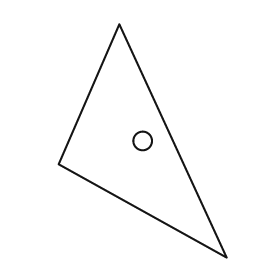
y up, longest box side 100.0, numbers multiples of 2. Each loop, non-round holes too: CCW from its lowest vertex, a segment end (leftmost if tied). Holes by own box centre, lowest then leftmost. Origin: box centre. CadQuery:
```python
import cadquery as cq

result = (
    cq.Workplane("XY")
    .moveTo(36.0, -50.0)
    .lineTo(-10.0, 50.0)
    .lineTo(-36.0, -10.0)
    .close()
    .moveTo(0.0, 0.0)
    .circle(4.0)
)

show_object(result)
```